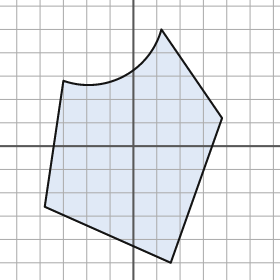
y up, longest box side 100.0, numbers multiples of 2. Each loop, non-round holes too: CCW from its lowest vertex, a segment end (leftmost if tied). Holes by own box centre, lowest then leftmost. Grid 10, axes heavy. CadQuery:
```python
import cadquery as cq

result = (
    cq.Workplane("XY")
    .moveTo(16.0, -50.0)
    .lineTo(38.0, 12.0)
    .lineTo(12.0, 50.0)
    .threePointArc((-4.0, 30.0), (-30.0, 28.0))
    .lineTo(-38.0, -26.0)
    .close()
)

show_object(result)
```